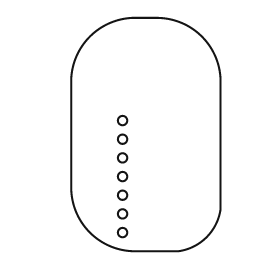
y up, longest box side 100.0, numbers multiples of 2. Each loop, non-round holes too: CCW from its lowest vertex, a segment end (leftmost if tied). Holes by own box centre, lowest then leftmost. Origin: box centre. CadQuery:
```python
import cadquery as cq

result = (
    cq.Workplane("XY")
    .moveTo(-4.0, -50.0)
    .lineTo(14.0, -50.0)
    .threePointArc((26.0, -44.0), (32.0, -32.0))
    .lineTo(32.0, 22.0)
    .threePointArc((24.0, 42.0), (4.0, 50.0))
    .lineTo(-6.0, 50.0)
    .threePointArc((-24.0, 42.0), (-32.0, 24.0))
    .lineTo(-32.0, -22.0)
    .threePointArc((-24.0, -42.0), (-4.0, -50.0))
    .close()
    .moveTo(-10.0, -42.0)
    .circle(2.0)
    .moveTo(-10.0, -34.0)
    .circle(2.0)
    .moveTo(-10.0, -26.0)
    .circle(2.0)
    .moveTo(-10.0, -18.0)
    .circle(2.0)
    .moveTo(-10.0, -10.0)
    .circle(2.0)
    .moveTo(-10.0, -2.0)
    .circle(2.0)
    .moveTo(-10.0, 6.0)
    .circle(2.0)
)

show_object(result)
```